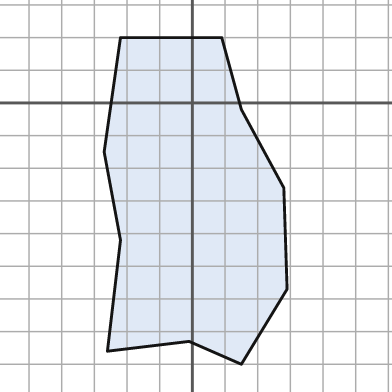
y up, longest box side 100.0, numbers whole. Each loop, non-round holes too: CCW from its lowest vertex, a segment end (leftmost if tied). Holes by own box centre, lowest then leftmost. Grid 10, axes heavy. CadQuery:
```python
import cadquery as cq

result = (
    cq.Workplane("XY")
    .moveTo(15.0, -80.0)
    .lineTo(29.0, -57.0)
    .lineTo(28.0, -26.0)
    .lineTo(15.0, -2.0)
    .lineTo(9.0, 20.0)
    .lineTo(-22.0, 20.0)
    .lineTo(-27.0, -15.0)
    .lineTo(-22.0, -42.0)
    .lineTo(-26.0, -76.0)
    .lineTo(-1.0, -73.0)
    .close()
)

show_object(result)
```